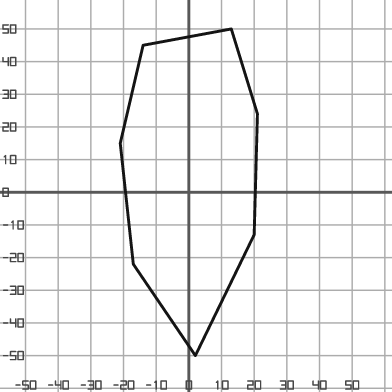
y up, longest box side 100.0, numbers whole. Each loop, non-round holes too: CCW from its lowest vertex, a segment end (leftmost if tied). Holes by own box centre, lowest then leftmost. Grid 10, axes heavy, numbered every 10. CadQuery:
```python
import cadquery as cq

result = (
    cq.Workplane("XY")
    .moveTo(2.0, -50.0)
    .lineTo(20.0, -13.0)
    .lineTo(21.0, 24.0)
    .lineTo(13.0, 50.0)
    .lineTo(-14.0, 45.0)
    .lineTo(-21.0, 15.0)
    .lineTo(-17.0, -22.0)
    .close()
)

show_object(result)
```